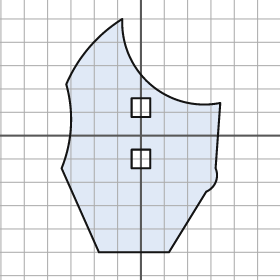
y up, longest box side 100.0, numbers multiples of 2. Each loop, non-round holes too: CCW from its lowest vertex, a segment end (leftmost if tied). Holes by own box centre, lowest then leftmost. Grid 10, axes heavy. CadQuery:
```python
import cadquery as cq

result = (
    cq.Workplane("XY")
    .moveTo(-18.0, -50.0)
    .lineTo(12.0, -50.0)
    .lineTo(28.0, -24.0)
    .threePointArc((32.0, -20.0), (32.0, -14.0))
    .lineTo(34.0, 14.0)
    .threePointArc((4.0, 22.0), (-8.0, 50.0))
    .threePointArc((-22.0, 38.0), (-32.0, 22.0))
    .threePointArc((-30.0, 4.0), (-34.0, -14.0))
    .close()
    .moveTo(-4.0, -14.0)
    .lineTo(4.0, -14.0)
    .lineTo(4.0, -6.0)
    .lineTo(-4.0, -6.0)
    .close()
    .moveTo(-4.0, 8.0)
    .lineTo(4.0, 8.0)
    .lineTo(4.0, 16.0)
    .lineTo(-4.0, 16.0)
    .close()
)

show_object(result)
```